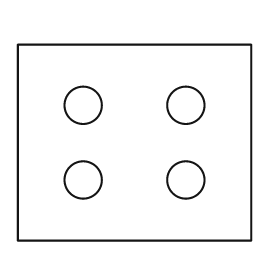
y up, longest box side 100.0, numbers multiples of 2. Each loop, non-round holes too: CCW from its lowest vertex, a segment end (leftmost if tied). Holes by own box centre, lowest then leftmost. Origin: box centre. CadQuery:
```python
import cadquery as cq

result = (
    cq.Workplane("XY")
    .moveTo(-50.0, -42.0)
    .lineTo(50.0, -42.0)
    .lineTo(50.0, 42.0)
    .lineTo(-50.0, 42.0)
    .close()
    .moveTo(-22.0, -16.0)
    .circle(8.0)
    .moveTo(22.0, -16.0)
    .circle(8.0)
    .moveTo(-22.0, 16.0)
    .circle(8.0)
    .moveTo(22.0, 16.0)
    .circle(8.0)
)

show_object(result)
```